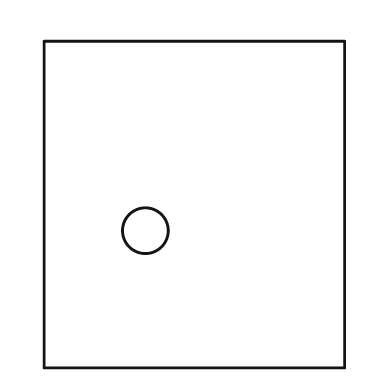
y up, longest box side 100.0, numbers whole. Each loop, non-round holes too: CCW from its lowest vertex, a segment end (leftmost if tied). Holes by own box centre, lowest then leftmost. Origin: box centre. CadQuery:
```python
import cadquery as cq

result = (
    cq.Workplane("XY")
    .moveTo(-46.0, -50.0)
    .lineTo(46.0, -50.0)
    .lineTo(46.0, 50.0)
    .lineTo(-46.0, 50.0)
    .close()
    .moveTo(-15.0, -8.0)
    .circle(7.0)
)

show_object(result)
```